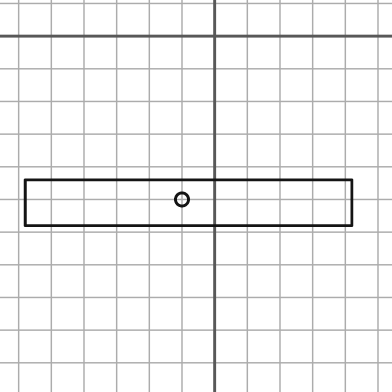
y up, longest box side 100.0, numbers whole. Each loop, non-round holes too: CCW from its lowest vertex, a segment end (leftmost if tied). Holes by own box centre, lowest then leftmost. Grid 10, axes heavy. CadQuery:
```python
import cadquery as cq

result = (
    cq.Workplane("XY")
    .moveTo(-58.0, -58.0)
    .lineTo(42.0, -58.0)
    .lineTo(42.0, -44.0)
    .lineTo(-58.0, -44.0)
    .close()
    .moveTo(-10.0, -50.0)
    .circle(2.0)
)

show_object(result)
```